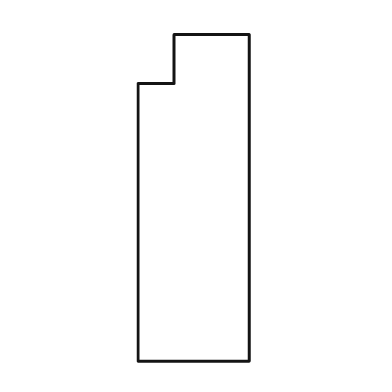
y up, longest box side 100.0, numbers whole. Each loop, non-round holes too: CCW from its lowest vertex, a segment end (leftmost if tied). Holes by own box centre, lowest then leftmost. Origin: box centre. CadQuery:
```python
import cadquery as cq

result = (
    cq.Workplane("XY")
    .moveTo(-17.0, -50.0)
    .lineTo(17.0, -50.0)
    .lineTo(17.0, 50.0)
    .lineTo(-6.0, 50.0)
    .lineTo(-6.0, 35.0)
    .lineTo(-17.0, 35.0)
    .close()
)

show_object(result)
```